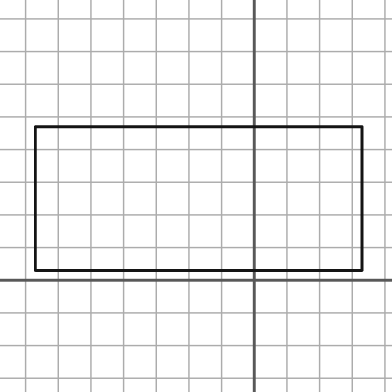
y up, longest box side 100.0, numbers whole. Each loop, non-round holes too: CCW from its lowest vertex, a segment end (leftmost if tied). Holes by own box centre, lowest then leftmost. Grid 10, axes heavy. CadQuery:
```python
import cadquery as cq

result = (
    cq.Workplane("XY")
    .moveTo(-67.0, 3.0)
    .lineTo(33.0, 3.0)
    .lineTo(33.0, 47.0)
    .lineTo(-67.0, 47.0)
    .close()
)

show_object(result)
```